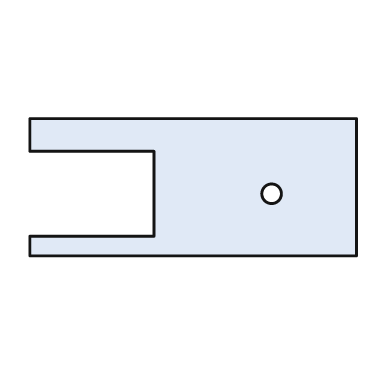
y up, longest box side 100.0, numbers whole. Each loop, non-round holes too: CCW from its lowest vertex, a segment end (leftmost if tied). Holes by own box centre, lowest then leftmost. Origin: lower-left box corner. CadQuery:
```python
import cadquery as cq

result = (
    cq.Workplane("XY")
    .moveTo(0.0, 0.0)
    .lineTo(100.0, 0.0)
    .lineTo(100.0, 42.0)
    .lineTo(0.0, 42.0)
    .lineTo(0.0, 32.0)
    .lineTo(38.0, 32.0)
    .lineTo(38.0, 6.0)
    .lineTo(0.0, 6.0)
    .close()
    .moveTo(74.0, 19.0)
    .circle(3.0)
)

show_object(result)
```